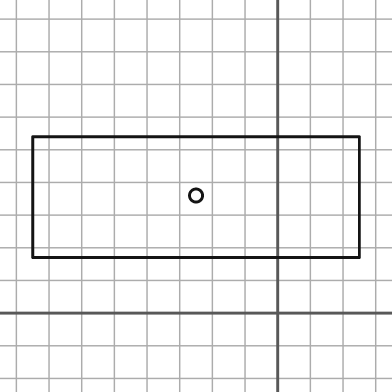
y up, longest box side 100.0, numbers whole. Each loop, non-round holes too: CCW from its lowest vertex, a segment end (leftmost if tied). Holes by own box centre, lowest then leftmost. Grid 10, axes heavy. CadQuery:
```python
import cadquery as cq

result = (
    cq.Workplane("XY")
    .moveTo(-75.0, 17.0)
    .lineTo(25.0, 17.0)
    .lineTo(25.0, 54.0)
    .lineTo(-75.0, 54.0)
    .close()
    .moveTo(-25.0, 36.0)
    .circle(2.0)
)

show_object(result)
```